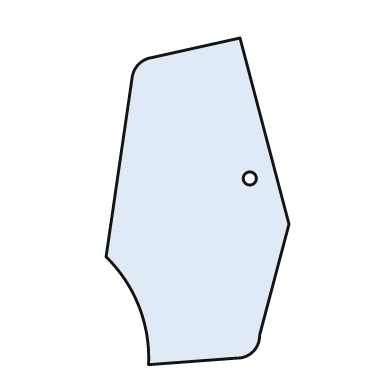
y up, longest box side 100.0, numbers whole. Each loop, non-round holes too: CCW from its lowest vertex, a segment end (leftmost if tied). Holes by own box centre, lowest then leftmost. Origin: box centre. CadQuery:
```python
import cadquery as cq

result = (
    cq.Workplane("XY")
    .moveTo(-15.0, -50.0)
    .lineTo(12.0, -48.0)
    .threePointArc((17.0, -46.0), (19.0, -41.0))
    .lineTo(28.0, -7.0)
    .lineTo(13.0, 50.0)
    .lineTo(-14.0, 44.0)
    .threePointArc((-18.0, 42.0), (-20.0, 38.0))
    .lineTo(-28.0, -17.0)
    .threePointArc((-18.0, -32.0), (-15.0, -50.0))
    .close()
    .moveTo(16.0, 7.0)
    .circle(2.0)
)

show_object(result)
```